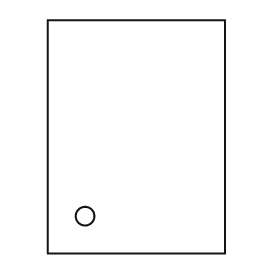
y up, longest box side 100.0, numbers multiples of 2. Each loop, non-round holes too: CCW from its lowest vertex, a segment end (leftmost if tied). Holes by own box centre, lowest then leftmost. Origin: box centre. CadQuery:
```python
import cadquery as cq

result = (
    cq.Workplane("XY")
    .moveTo(-38.0, -50.0)
    .lineTo(38.0, -50.0)
    .lineTo(38.0, 50.0)
    .lineTo(-38.0, 50.0)
    .close()
    .moveTo(-22.0, -34.0)
    .circle(4.0)
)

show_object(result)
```